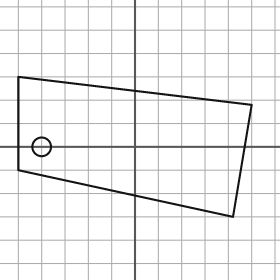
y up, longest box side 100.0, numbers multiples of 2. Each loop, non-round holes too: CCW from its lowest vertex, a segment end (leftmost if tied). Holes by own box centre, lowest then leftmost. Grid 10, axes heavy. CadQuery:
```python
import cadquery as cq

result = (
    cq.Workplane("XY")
    .moveTo(42.0, -30.0)
    .lineTo(50.0, 18.0)
    .lineTo(-50.0, 30.0)
    .lineTo(-50.0, -10.0)
    .close()
    .moveTo(-40.0, 0.0)
    .circle(4.0)
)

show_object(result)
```